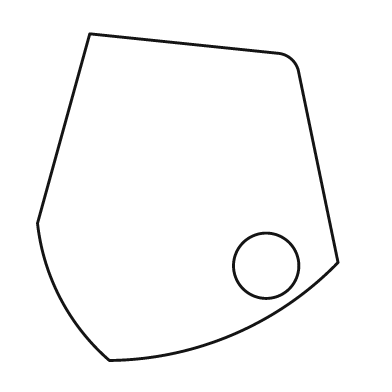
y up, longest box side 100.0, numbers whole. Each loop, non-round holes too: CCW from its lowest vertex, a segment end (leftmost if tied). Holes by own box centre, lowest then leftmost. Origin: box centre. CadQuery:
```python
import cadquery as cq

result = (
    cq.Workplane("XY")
    .moveTo(-24.0, -50.0)
    .threePointArc((14.0, -42.0), (46.0, -20.0))
    .lineTo(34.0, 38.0)
    .threePointArc((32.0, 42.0), (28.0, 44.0))
    .lineTo(-30.0, 50.0)
    .lineTo(-46.0, -8.0)
    .threePointArc((-39.0, -31.0), (-24.0, -50.0))
    .close()
    .moveTo(24.0, -21.0)
    .circle(10.0)
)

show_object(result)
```